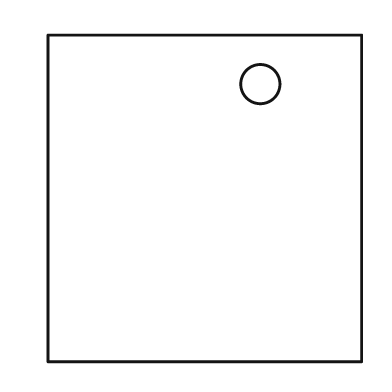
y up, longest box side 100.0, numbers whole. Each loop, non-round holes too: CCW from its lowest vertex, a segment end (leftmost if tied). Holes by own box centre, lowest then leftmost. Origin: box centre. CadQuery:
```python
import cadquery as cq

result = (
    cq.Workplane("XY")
    .moveTo(-48.0, -50.0)
    .lineTo(48.0, -50.0)
    .lineTo(48.0, 50.0)
    .lineTo(-48.0, 50.0)
    .close()
    .moveTo(17.0, 35.0)
    .circle(6.0)
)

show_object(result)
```